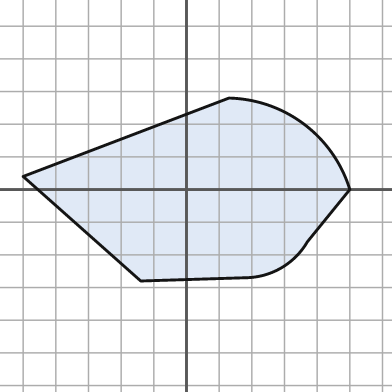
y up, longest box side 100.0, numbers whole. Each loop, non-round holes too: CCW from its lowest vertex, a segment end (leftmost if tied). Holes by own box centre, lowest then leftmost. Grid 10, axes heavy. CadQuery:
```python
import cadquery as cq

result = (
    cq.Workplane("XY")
    .moveTo(-14.0, -28.0)
    .lineTo(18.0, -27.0)
    .threePointArc((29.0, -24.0), (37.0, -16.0))
    .lineTo(50.0, 0.0)
    .threePointArc((36.0, 20.0), (13.0, 28.0))
    .lineTo(-50.0, 4.0)
    .close()
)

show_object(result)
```